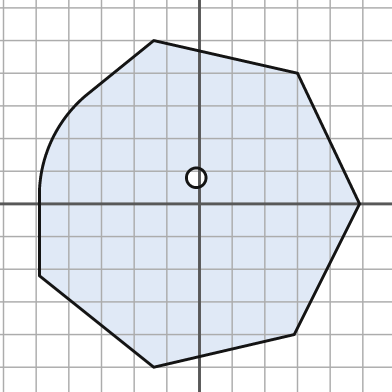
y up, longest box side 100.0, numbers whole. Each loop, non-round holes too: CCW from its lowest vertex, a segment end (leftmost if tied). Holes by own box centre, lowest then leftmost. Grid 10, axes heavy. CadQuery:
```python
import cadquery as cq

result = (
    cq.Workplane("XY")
    .moveTo(-14.0, -50.0)
    .lineTo(29.0, -40.0)
    .lineTo(49.0, 0.0)
    .lineTo(30.0, 40.0)
    .lineTo(-14.0, 50.0)
    .lineTo(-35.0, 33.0)
    .threePointArc((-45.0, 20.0), (-49.0, 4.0))
    .lineTo(-49.0, -22.0)
    .close()
    .moveTo(-1.0, 8.0)
    .circle(3.0)
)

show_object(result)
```